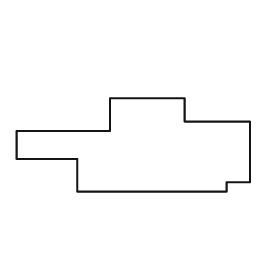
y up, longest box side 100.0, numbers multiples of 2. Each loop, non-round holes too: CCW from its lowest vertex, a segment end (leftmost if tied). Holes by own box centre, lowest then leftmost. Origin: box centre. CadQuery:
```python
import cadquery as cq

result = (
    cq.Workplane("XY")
    .moveTo(-24.0, -20.0)
    .lineTo(40.0, -20.0)
    .lineTo(40.0, -16.0)
    .lineTo(50.0, -16.0)
    .lineTo(50.0, 10.0)
    .lineTo(22.0, 10.0)
    .lineTo(22.0, 20.0)
    .lineTo(-10.0, 20.0)
    .lineTo(-10.0, 6.0)
    .lineTo(-50.0, 6.0)
    .lineTo(-50.0, -6.0)
    .lineTo(-24.0, -6.0)
    .close()
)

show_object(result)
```